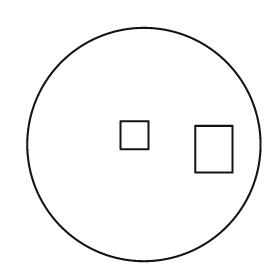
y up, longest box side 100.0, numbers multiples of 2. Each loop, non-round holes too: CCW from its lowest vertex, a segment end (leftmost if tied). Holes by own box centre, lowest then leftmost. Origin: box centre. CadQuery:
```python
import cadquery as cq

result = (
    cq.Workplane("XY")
    .moveTo(0.0, 0.0)
    .circle(50.0)
    .moveTo(22.0, -12.0)
    .lineTo(38.0, -12.0)
    .lineTo(38.0, 8.0)
    .lineTo(22.0, 8.0)
    .close()
    .moveTo(-10.0, -2.0)
    .lineTo(2.0, -2.0)
    .lineTo(2.0, 10.0)
    .lineTo(-10.0, 10.0)
    .close()
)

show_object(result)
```